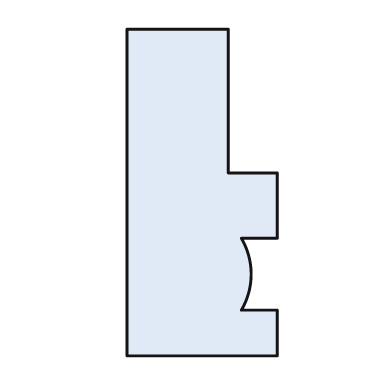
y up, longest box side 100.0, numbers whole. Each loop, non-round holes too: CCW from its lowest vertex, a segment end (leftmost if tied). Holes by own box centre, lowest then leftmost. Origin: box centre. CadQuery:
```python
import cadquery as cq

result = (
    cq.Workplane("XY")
    .moveTo(-23.0, -50.0)
    .lineTo(23.0, -50.0)
    .lineTo(23.0, -36.0)
    .lineTo(12.0, -36.0)
    .threePointArc((15.0, -25.0), (12.0, -14.0))
    .lineTo(23.0, -14.0)
    .lineTo(23.0, 6.0)
    .lineTo(8.0, 6.0)
    .lineTo(8.0, 50.0)
    .lineTo(-23.0, 50.0)
    .close()
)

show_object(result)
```